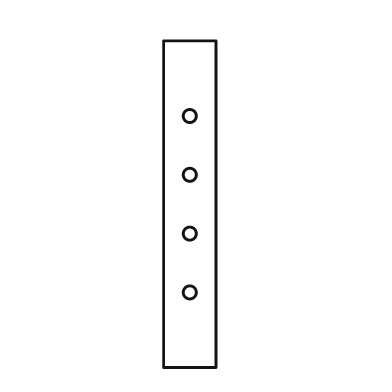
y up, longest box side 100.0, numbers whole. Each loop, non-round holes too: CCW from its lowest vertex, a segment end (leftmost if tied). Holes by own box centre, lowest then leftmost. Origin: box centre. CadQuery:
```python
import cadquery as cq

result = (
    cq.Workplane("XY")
    .moveTo(-8.0, -50.0)
    .lineTo(8.0, -50.0)
    .lineTo(8.0, 50.0)
    .lineTo(-8.0, 50.0)
    .close()
    .moveTo(0.0, -27.0)
    .circle(2.0)
    .moveTo(0.0, -9.0)
    .circle(2.0)
    .moveTo(0.0, 9.0)
    .circle(2.0)
    .moveTo(0.0, 27.0)
    .circle(2.0)
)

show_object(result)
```